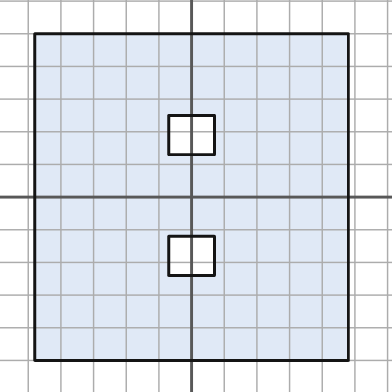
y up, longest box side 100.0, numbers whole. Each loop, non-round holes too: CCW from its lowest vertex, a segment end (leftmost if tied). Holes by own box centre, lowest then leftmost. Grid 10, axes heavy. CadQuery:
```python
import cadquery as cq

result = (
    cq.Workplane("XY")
    .moveTo(-48.0, -50.0)
    .lineTo(48.0, -50.0)
    .lineTo(48.0, 50.0)
    .lineTo(-48.0, 50.0)
    .close()
    .moveTo(-7.0, -24.0)
    .lineTo(7.0, -24.0)
    .lineTo(7.0, -12.0)
    .lineTo(-7.0, -12.0)
    .close()
    .moveTo(-7.0, 13.0)
    .lineTo(7.0, 13.0)
    .lineTo(7.0, 25.0)
    .lineTo(-7.0, 25.0)
    .close()
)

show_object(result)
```